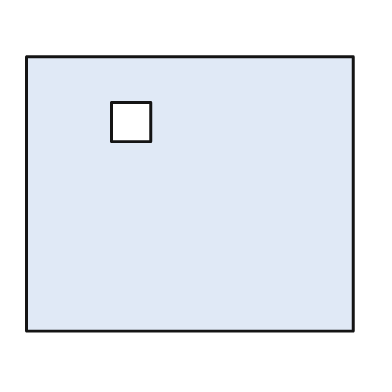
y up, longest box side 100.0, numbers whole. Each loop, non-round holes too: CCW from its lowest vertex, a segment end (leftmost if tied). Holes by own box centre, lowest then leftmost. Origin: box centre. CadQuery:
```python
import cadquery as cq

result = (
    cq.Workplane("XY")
    .moveTo(-50.0, -42.0)
    .lineTo(50.0, -42.0)
    .lineTo(50.0, 42.0)
    .lineTo(-50.0, 42.0)
    .close()
    .moveTo(-24.0, 16.0)
    .lineTo(-12.0, 16.0)
    .lineTo(-12.0, 28.0)
    .lineTo(-24.0, 28.0)
    .close()
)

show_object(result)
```